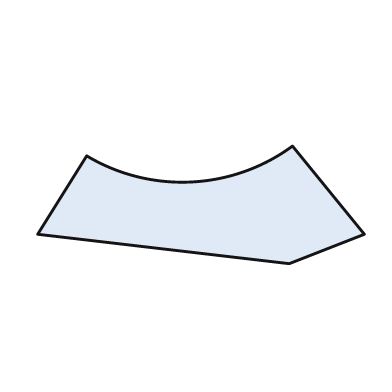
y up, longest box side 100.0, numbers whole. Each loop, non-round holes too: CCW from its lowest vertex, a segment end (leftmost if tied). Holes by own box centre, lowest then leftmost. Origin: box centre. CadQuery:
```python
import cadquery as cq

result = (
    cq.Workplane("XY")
    .moveTo(27.0, -18.0)
    .lineTo(50.0, -9.0)
    .lineTo(28.0, 18.0)
    .threePointArc((-3.0, 7.0), (-35.0, 15.0))
    .lineTo(-50.0, -9.0)
    .close()
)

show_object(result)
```